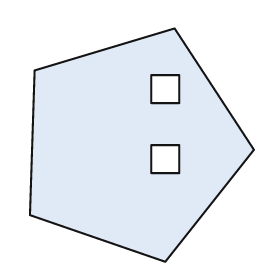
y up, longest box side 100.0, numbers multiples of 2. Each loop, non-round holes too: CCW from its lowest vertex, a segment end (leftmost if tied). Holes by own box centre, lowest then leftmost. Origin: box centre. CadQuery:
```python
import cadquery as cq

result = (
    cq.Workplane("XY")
    .moveTo(10.0, -50.0)
    .lineTo(48.0, -2.0)
    .lineTo(14.0, 50.0)
    .lineTo(-46.0, 32.0)
    .lineTo(-48.0, -30.0)
    .close()
    .moveTo(4.0, -12.0)
    .lineTo(16.0, -12.0)
    .lineTo(16.0, 0.0)
    .lineTo(4.0, 0.0)
    .close()
    .moveTo(4.0, 18.0)
    .lineTo(16.0, 18.0)
    .lineTo(16.0, 30.0)
    .lineTo(4.0, 30.0)
    .close()
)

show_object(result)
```